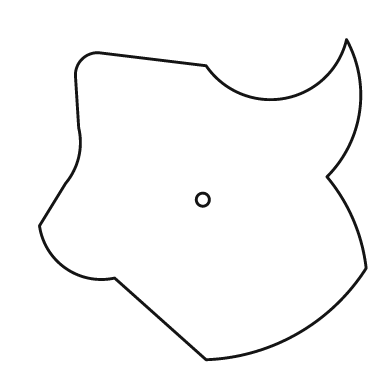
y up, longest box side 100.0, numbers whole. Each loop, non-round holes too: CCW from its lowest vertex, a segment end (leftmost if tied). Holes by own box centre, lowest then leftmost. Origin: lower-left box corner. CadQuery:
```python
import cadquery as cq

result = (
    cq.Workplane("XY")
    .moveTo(51.0, 0.0)
    .threePointArc((79.0, 8.0), (100.0, 28.0))
    .threePointArc((96.0, 43.0), (88.0, 56.0))
    .threePointArc((98.0, 76.0), (94.0, 98.0))
    .threePointArc((75.0, 80.0), (51.0, 90.0))
    .lineTo(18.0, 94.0)
    .threePointArc((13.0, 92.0), (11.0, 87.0))
    .lineTo(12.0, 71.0)
    .threePointArc((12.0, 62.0), (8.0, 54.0))
    .lineTo(0.0, 41.0)
    .threePointArc((8.0, 28.0), (23.0, 25.0))
    .close()
    .moveTo(50.0, 49.0)
    .circle(2.0)
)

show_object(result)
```